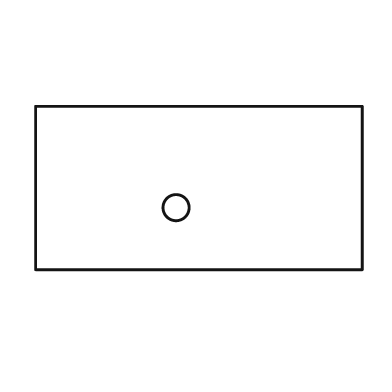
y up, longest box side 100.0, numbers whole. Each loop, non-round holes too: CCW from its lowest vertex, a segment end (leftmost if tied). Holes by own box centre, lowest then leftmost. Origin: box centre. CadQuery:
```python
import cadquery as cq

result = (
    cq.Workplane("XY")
    .moveTo(-50.0, -25.0)
    .lineTo(50.0, -25.0)
    .lineTo(50.0, 25.0)
    .lineTo(-50.0, 25.0)
    .close()
    .moveTo(-7.0, -6.0)
    .circle(4.0)
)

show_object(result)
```